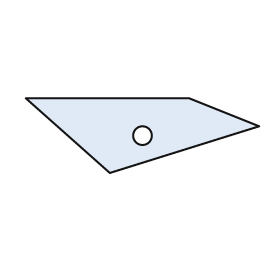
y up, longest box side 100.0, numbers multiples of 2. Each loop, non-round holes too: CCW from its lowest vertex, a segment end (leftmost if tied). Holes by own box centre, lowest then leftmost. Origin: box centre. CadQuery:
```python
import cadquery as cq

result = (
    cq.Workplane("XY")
    .moveTo(-14.0, -16.0)
    .lineTo(50.0, 4.0)
    .lineTo(20.0, 16.0)
    .lineTo(-50.0, 16.0)
    .close()
    .moveTo(0.0, 0.0)
    .circle(4.0)
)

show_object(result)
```